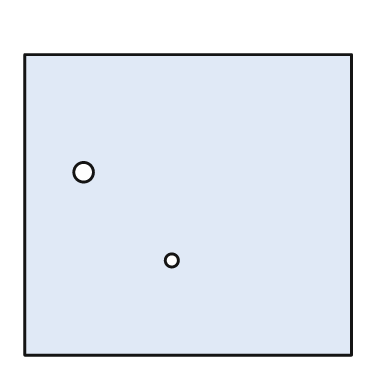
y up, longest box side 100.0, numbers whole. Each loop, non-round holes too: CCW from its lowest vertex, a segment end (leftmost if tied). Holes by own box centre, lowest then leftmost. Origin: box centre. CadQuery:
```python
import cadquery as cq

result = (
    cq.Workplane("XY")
    .moveTo(-50.0, -46.0)
    .lineTo(50.0, -46.0)
    .lineTo(50.0, 46.0)
    .lineTo(-50.0, 46.0)
    .close()
    .moveTo(-5.0, -17.0)
    .circle(2.0)
    .moveTo(-32.0, 10.0)
    .circle(3.0)
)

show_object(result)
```